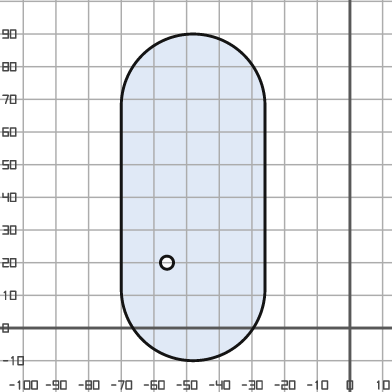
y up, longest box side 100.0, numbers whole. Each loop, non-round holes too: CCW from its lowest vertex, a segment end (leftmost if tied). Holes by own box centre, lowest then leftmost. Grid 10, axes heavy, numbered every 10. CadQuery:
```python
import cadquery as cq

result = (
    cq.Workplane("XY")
    .moveTo(-70.0, 12.0)
    .threePointArc((-48.0, -10.0), (-26.0, 12.0))
    .lineTo(-26.0, 68.0)
    .threePointArc((-48.0, 90.0), (-70.0, 68.0))
    .close()
    .moveTo(-56.0, 20.0)
    .circle(2.0)
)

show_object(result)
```